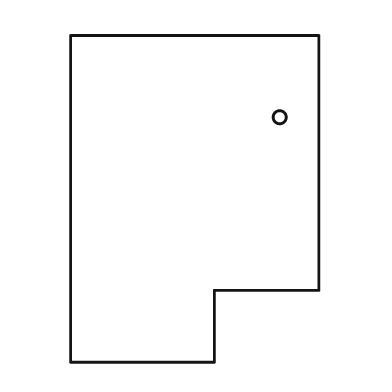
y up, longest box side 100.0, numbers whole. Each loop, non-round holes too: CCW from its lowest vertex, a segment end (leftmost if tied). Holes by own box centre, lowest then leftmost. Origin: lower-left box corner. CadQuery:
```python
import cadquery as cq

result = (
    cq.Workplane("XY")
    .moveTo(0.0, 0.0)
    .lineTo(44.0, 0.0)
    .lineTo(44.0, 22.0)
    .lineTo(76.0, 22.0)
    .lineTo(76.0, 100.0)
    .lineTo(0.0, 100.0)
    .close()
    .moveTo(64.0, 75.0)
    .circle(2.0)
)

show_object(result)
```